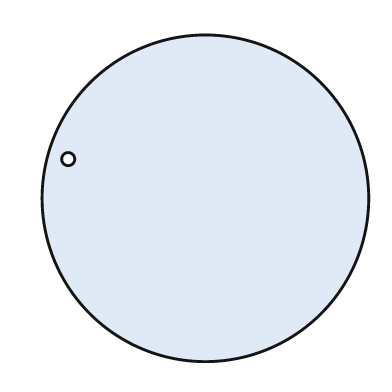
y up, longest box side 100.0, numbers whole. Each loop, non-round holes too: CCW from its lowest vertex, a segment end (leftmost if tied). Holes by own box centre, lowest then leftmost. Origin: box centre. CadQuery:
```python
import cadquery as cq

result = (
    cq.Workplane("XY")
    .moveTo(0.0, 0.0)
    .circle(50.0)
    .moveTo(-42.0, 12.0)
    .circle(2.0)
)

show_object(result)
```